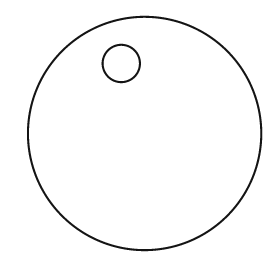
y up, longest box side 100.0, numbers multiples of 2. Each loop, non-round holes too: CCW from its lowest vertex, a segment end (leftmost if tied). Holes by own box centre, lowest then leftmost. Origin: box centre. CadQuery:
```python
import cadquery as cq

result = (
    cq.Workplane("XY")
    .moveTo(0.0, 0.0)
    .circle(50.0)
    .moveTo(-10.0, 30.0)
    .circle(8.0)
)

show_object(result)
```